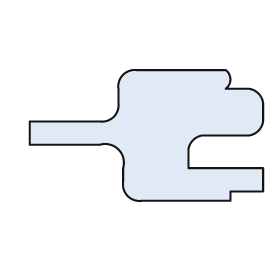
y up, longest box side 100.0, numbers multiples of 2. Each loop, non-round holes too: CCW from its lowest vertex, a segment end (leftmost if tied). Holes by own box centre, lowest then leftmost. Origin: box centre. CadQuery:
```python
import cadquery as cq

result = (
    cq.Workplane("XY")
    .moveTo(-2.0, -28.0)
    .lineTo(36.0, -28.0)
    .lineTo(36.0, -24.0)
    .lineTo(50.0, -24.0)
    .lineTo(50.0, -14.0)
    .lineTo(18.0, -14.0)
    .lineTo(18.0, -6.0)
    .threePointArc((20.0, -2.0), (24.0, 0.0))
    .lineTo(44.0, 0.0)
    .threePointArc((48.0, 2.0), (50.0, 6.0))
    .lineTo(50.0, 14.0)
    .threePointArc((48.0, 18.0), (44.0, 20.0))
    .lineTo(34.0, 20.0)
    .threePointArc((36.0, 24.0), (34.0, 28.0))
    .lineTo(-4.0, 28.0)
    .threePointArc((-10.0, 26.0), (-12.0, 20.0))
    .lineTo(-12.0, 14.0)
    .threePointArc((-14.0, 8.0), (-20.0, 6.0))
    .lineTo(-50.0, 6.0)
    .lineTo(-50.0, -4.0)
    .lineTo(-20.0, -4.0)
    .threePointArc((-12.0, -6.0), (-10.0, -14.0))
    .lineTo(-10.0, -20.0)
    .threePointArc((-8.0, -26.0), (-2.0, -28.0))
    .close()
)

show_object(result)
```